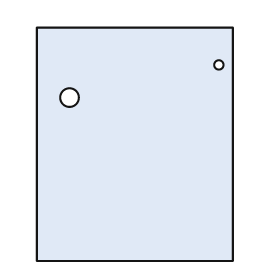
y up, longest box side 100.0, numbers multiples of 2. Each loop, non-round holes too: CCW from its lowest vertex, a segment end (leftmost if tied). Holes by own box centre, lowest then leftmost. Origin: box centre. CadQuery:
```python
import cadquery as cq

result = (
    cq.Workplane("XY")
    .moveTo(-42.0, -50.0)
    .lineTo(42.0, -50.0)
    .lineTo(42.0, 50.0)
    .lineTo(-42.0, 50.0)
    .close()
    .moveTo(-28.0, 20.0)
    .circle(4.0)
    .moveTo(36.0, 34.0)
    .circle(2.0)
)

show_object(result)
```